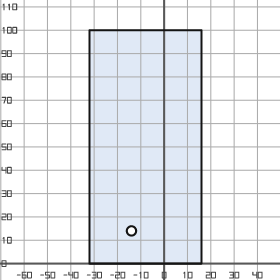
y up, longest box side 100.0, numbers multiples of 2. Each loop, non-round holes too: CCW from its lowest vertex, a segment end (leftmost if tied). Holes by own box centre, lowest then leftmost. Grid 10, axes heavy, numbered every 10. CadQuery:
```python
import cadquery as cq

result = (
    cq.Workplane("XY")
    .moveTo(-32.0, 0.0)
    .lineTo(16.0, 0.0)
    .lineTo(16.0, 100.0)
    .lineTo(-32.0, 100.0)
    .close()
    .moveTo(-14.0, 14.0)
    .circle(2.0)
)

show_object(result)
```